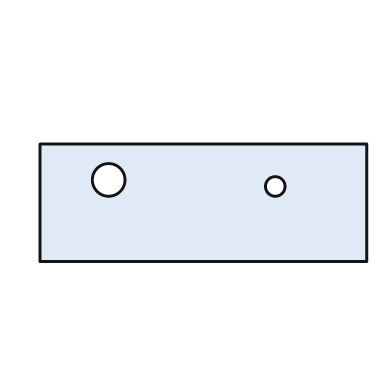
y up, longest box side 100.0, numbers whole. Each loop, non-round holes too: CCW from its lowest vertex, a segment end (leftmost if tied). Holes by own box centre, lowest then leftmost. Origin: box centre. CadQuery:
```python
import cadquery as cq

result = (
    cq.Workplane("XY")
    .moveTo(-50.0, -18.0)
    .lineTo(50.0, -18.0)
    .lineTo(50.0, 18.0)
    .lineTo(-50.0, 18.0)
    .close()
    .moveTo(22.0, 5.0)
    .circle(3.0)
    .moveTo(-29.0, 7.0)
    .circle(5.0)
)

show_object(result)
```